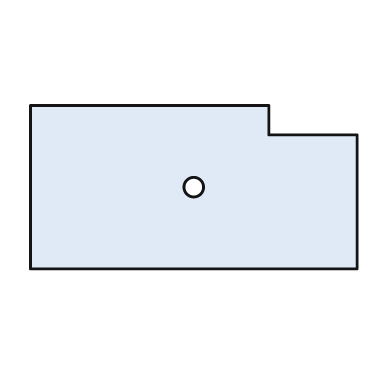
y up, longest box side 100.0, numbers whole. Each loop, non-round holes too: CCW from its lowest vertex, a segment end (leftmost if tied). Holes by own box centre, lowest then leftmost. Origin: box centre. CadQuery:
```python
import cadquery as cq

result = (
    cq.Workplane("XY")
    .moveTo(-50.0, -25.0)
    .lineTo(50.0, -25.0)
    .lineTo(50.0, 16.0)
    .lineTo(23.0, 16.0)
    .lineTo(23.0, 25.0)
    .lineTo(-50.0, 25.0)
    .close()
    .moveTo(0.0, 0.0)
    .circle(3.0)
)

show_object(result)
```